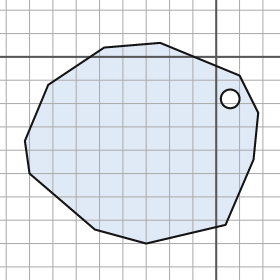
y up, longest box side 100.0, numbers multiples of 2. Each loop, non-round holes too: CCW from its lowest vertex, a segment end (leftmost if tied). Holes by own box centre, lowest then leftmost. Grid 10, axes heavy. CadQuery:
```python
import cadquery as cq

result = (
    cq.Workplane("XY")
    .moveTo(-30.0, -80.0)
    .lineTo(4.0, -72.0)
    .lineTo(16.0, -44.0)
    .lineTo(18.0, -24.0)
    .lineTo(10.0, -8.0)
    .lineTo(-24.0, 6.0)
    .lineTo(-48.0, 4.0)
    .lineTo(-72.0, -12.0)
    .lineTo(-82.0, -36.0)
    .lineTo(-80.0, -50.0)
    .lineTo(-52.0, -74.0)
    .close()
    .moveTo(6.0, -18.0)
    .circle(4.0)
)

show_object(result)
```